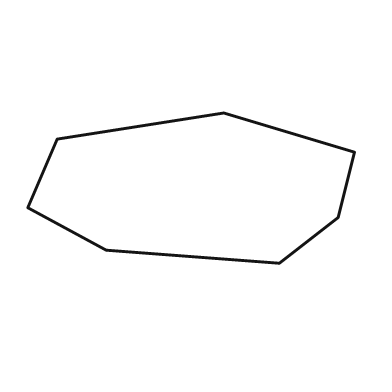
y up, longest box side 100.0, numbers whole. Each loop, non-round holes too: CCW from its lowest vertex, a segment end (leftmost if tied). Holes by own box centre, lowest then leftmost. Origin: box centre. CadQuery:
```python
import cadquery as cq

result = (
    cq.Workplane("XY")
    .moveTo(27.0, -23.0)
    .lineTo(45.0, -9.0)
    .lineTo(50.0, 11.0)
    .lineTo(10.0, 23.0)
    .lineTo(-41.0, 15.0)
    .lineTo(-50.0, -6.0)
    .lineTo(-26.0, -19.0)
    .close()
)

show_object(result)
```